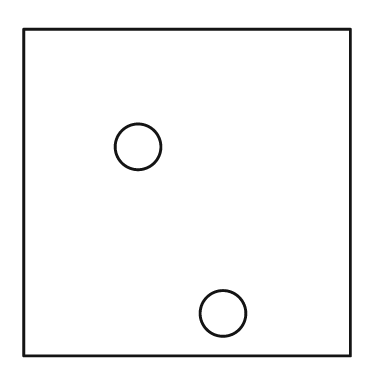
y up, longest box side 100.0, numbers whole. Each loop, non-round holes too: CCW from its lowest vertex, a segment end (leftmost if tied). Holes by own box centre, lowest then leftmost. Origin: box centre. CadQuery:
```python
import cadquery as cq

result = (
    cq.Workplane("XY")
    .moveTo(-50.0, -50.0)
    .lineTo(50.0, -50.0)
    .lineTo(50.0, 50.0)
    .lineTo(-50.0, 50.0)
    .close()
    .moveTo(11.0, -37.0)
    .circle(7.0)
    .moveTo(-15.0, 14.0)
    .circle(7.0)
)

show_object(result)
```